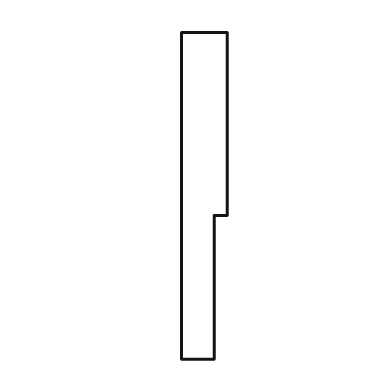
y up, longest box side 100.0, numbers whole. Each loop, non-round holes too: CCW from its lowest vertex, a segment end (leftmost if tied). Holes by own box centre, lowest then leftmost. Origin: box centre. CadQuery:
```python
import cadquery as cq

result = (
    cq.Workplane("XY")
    .moveTo(-7.0, -50.0)
    .lineTo(3.0, -50.0)
    .lineTo(3.0, -6.0)
    .lineTo(7.0, -6.0)
    .lineTo(7.0, 50.0)
    .lineTo(-7.0, 50.0)
    .close()
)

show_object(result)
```